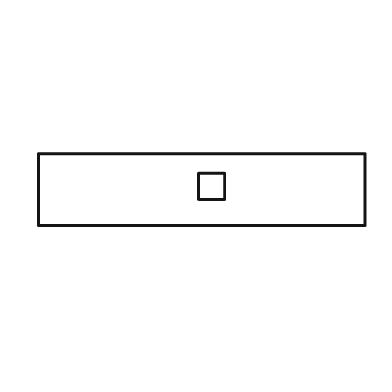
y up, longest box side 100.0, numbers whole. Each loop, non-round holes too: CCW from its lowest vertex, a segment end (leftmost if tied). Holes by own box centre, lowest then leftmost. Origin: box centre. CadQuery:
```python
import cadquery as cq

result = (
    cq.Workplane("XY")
    .moveTo(-50.0, -11.0)
    .lineTo(50.0, -11.0)
    .lineTo(50.0, 11.0)
    .lineTo(-50.0, 11.0)
    .close()
    .moveTo(-1.0, -3.0)
    .lineTo(7.0, -3.0)
    .lineTo(7.0, 5.0)
    .lineTo(-1.0, 5.0)
    .close()
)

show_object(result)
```